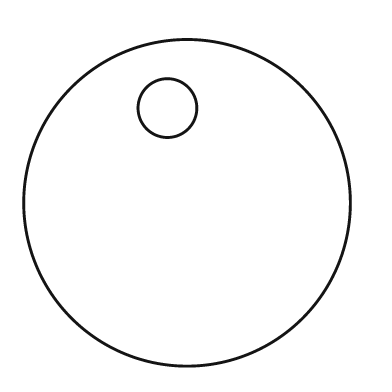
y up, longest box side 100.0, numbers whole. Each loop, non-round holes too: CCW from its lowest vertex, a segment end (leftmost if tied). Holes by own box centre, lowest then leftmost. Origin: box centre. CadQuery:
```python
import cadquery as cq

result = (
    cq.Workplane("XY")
    .moveTo(0.0, 0.0)
    .circle(50.0)
    .moveTo(-6.0, 29.0)
    .circle(9.0)
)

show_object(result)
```